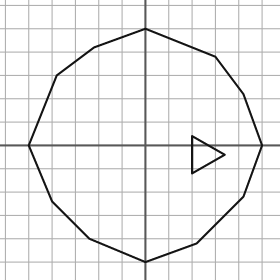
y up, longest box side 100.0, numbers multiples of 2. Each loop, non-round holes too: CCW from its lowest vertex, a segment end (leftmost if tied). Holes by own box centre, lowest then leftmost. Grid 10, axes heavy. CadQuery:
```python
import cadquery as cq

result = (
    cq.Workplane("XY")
    .moveTo(0.0, -50.0)
    .lineTo(22.0, -42.0)
    .lineTo(42.0, -22.0)
    .lineTo(50.0, 0.0)
    .lineTo(42.0, 22.0)
    .lineTo(30.0, 38.0)
    .lineTo(0.0, 50.0)
    .lineTo(-22.0, 42.0)
    .lineTo(-38.0, 30.0)
    .lineTo(-50.0, 0.0)
    .lineTo(-40.0, -24.0)
    .lineTo(-24.0, -40.0)
    .close()
    .moveTo(20.0, -12.0)
    .lineTo(34.0, -4.0)
    .lineTo(20.0, 4.0)
    .close()
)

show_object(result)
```